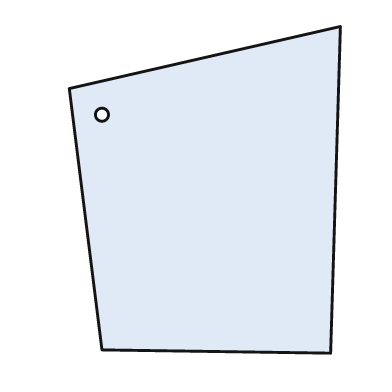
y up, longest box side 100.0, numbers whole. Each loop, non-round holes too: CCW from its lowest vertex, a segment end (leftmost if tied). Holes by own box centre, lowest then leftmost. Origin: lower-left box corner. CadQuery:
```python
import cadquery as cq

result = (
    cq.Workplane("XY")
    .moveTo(80.0, 0.0)
    .lineTo(83.0, 100.0)
    .lineTo(0.0, 81.0)
    .lineTo(10.0, 1.0)
    .close()
    .moveTo(10.0, 73.0)
    .circle(2.0)
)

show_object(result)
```